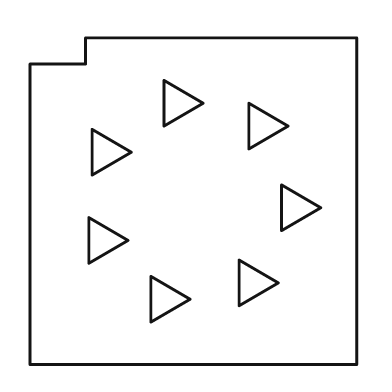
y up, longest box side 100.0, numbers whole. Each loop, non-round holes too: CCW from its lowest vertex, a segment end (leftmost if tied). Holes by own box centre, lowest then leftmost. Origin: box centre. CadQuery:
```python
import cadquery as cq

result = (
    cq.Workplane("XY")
    .moveTo(-50.0, -50.0)
    .lineTo(50.0, -50.0)
    .lineTo(50.0, 50.0)
    .lineTo(-33.0, 50.0)
    .lineTo(-33.0, 42.0)
    .lineTo(-50.0, 42.0)
    .close()
    .moveTo(-13.0, -37.0)
    .lineTo(-1.0, -30.0)
    .lineTo(-13.0, -23.0)
    .close()
    .moveTo(14.0, -32.0)
    .lineTo(26.0, -25.0)
    .lineTo(14.0, -18.0)
    .close()
    .moveTo(-32.0, -19.0)
    .lineTo(-20.0, -12.0)
    .lineTo(-32.0, -5.0)
    .close()
    .moveTo(27.0, -9.0)
    .lineTo(39.0, -2.0)
    .lineTo(27.0, 5.0)
    .close()
    .moveTo(-31.0, 8.0)
    .lineTo(-19.0, 15.0)
    .lineTo(-31.0, 22.0)
    .close()
    .moveTo(17.0, 16.0)
    .lineTo(29.0, 23.0)
    .lineTo(17.0, 30.0)
    .close()
    .moveTo(-9.0, 23.0)
    .lineTo(3.0, 30.0)
    .lineTo(-9.0, 37.0)
    .close()
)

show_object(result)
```